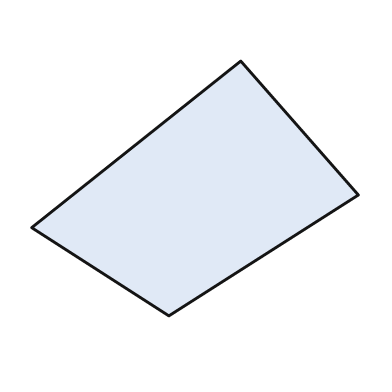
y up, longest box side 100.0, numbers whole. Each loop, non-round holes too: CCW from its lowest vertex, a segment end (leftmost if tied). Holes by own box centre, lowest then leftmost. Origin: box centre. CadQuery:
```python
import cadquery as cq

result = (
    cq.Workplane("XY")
    .moveTo(-8.0, -39.0)
    .lineTo(50.0, -2.0)
    .lineTo(14.0, 39.0)
    .lineTo(-50.0, -12.0)
    .close()
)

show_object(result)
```